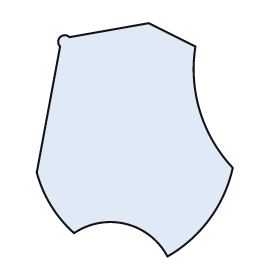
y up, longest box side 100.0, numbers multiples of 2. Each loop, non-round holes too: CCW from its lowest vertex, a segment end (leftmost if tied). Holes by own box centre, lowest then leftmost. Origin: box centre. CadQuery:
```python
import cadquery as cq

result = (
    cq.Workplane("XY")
    .moveTo(14.0, -50.0)
    .threePointArc((32.0, -34.0), (42.0, -12.0))
    .threePointArc((28.0, 12.0), (26.0, 40.0))
    .lineTo(6.0, 50.0)
    .lineTo(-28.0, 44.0)
    .threePointArc((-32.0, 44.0), (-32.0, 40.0))
    .lineTo(-42.0, -14.0)
    .threePointArc((-36.0, -28.0), (-26.0, -40.0))
    .threePointArc((-4.0, -36.0), (14.0, -50.0))
    .close()
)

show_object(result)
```